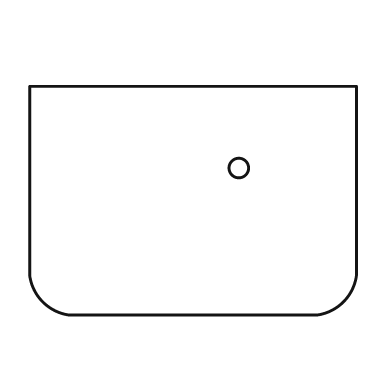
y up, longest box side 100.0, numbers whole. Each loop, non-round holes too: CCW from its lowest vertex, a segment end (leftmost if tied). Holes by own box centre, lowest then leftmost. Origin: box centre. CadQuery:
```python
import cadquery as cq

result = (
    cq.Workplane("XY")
    .moveTo(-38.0, -35.0)
    .lineTo(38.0, -35.0)
    .threePointArc((46.0, -31.0), (50.0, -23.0))
    .lineTo(50.0, 35.0)
    .lineTo(-50.0, 35.0)
    .lineTo(-50.0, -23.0)
    .threePointArc((-46.0, -31.0), (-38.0, -35.0))
    .close()
    .moveTo(14.0, 10.0)
    .circle(3.0)
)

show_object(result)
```